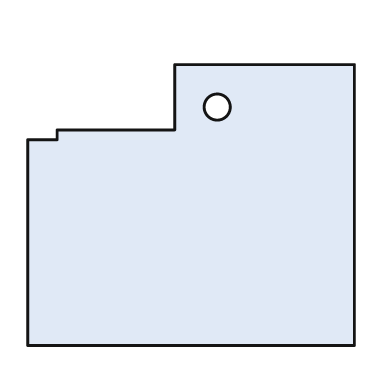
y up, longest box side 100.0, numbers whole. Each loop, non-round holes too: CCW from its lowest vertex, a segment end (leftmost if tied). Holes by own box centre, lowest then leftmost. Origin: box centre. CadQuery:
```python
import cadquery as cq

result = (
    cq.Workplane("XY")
    .moveTo(-50.0, -43.0)
    .lineTo(50.0, -43.0)
    .lineTo(50.0, 43.0)
    .lineTo(-5.0, 43.0)
    .lineTo(-5.0, 23.0)
    .lineTo(-41.0, 23.0)
    .lineTo(-41.0, 20.0)
    .lineTo(-50.0, 20.0)
    .close()
    .moveTo(8.0, 30.0)
    .circle(4.0)
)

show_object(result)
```